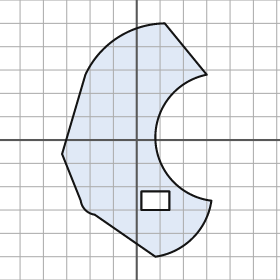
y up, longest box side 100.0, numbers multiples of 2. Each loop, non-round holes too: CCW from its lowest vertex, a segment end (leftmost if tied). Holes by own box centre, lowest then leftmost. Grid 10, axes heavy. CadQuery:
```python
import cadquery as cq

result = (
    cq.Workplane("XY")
    .moveTo(8.0, -50.0)
    .threePointArc((24.0, -42.0), (32.0, -26.0))
    .threePointArc((8.0, 0.0), (30.0, 28.0))
    .lineTo(12.0, 50.0)
    .threePointArc((-8.0, 44.0), (-22.0, 28.0))
    .lineTo(-32.0, -6.0)
    .lineTo(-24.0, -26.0)
    .threePointArc((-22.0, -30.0), (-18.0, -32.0))
    .close()
    .moveTo(2.0, -30.0)
    .lineTo(14.0, -30.0)
    .lineTo(14.0, -22.0)
    .lineTo(2.0, -22.0)
    .close()
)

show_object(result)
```